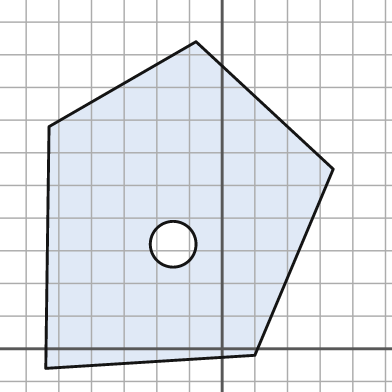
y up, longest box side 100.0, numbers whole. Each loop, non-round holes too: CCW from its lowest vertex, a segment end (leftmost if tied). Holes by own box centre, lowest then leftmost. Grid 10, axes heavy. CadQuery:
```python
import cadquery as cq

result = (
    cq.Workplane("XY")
    .moveTo(-54.0, -6.0)
    .lineTo(10.0, -2.0)
    .lineTo(34.0, 55.0)
    .lineTo(-8.0, 94.0)
    .lineTo(-53.0, 68.0)
    .close()
    .moveTo(-15.0, 32.0)
    .circle(7.0)
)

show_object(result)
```